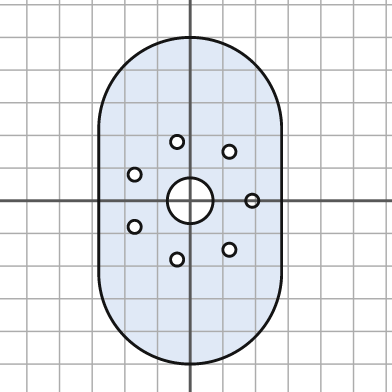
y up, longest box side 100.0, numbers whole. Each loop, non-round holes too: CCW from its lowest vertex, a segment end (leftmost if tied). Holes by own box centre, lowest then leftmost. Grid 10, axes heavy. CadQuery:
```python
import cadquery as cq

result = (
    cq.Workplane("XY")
    .moveTo(-28.0, -22.0)
    .threePointArc((0.0, -50.0), (28.0, -22.0))
    .lineTo(28.0, 22.0)
    .threePointArc((0.0, 50.0), (-28.0, 22.0))
    .close()
    .moveTo(-4.0, -18.0)
    .circle(2.0)
    .moveTo(12.0, -15.0)
    .circle(2.0)
    .moveTo(-17.0, -8.0)
    .circle(2.0)
    .moveTo(0.0, 0.0)
    .circle(7.0)
    .moveTo(19.0, 0.0)
    .circle(2.0)
    .moveTo(-17.0, 8.0)
    .circle(2.0)
    .moveTo(12.0, 15.0)
    .circle(2.0)
    .moveTo(-4.0, 18.0)
    .circle(2.0)
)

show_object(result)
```